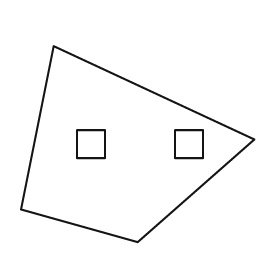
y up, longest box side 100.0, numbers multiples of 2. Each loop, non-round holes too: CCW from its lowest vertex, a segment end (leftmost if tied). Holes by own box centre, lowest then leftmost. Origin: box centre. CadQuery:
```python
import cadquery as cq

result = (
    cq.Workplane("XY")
    .moveTo(0.0, -42.0)
    .lineTo(50.0, 2.0)
    .lineTo(-36.0, 42.0)
    .lineTo(-50.0, -28.0)
    .close()
    .moveTo(-26.0, -6.0)
    .lineTo(-14.0, -6.0)
    .lineTo(-14.0, 6.0)
    .lineTo(-26.0, 6.0)
    .close()
    .moveTo(16.0, -6.0)
    .lineTo(28.0, -6.0)
    .lineTo(28.0, 6.0)
    .lineTo(16.0, 6.0)
    .close()
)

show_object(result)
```